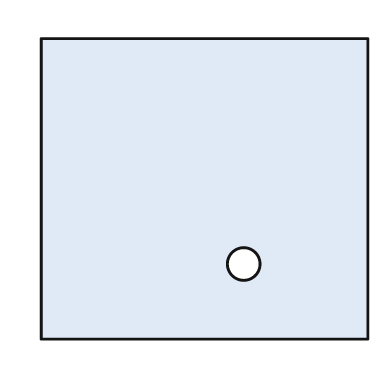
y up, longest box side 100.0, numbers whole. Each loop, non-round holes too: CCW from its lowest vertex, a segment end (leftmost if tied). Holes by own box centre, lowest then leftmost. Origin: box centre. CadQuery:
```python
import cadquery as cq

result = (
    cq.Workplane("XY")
    .moveTo(-50.0, -46.0)
    .lineTo(50.0, -46.0)
    .lineTo(50.0, 46.0)
    .lineTo(-50.0, 46.0)
    .close()
    .moveTo(12.0, -23.0)
    .circle(5.0)
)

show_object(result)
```